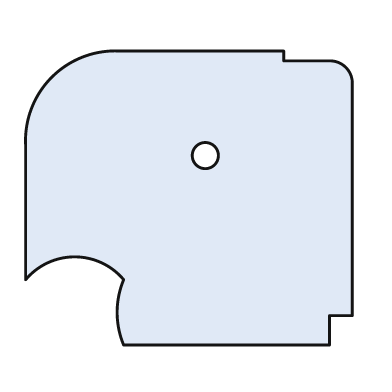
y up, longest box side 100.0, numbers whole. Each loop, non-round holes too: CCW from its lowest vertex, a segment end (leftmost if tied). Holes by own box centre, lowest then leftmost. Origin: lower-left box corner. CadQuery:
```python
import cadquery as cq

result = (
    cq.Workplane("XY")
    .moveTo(30.0, 0.0)
    .lineTo(93.0, 0.0)
    .lineTo(93.0, 9.0)
    .lineTo(100.0, 9.0)
    .lineTo(100.0, 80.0)
    .threePointArc((98.0, 85.0), (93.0, 87.0))
    .lineTo(79.0, 87.0)
    .lineTo(79.0, 90.0)
    .lineTo(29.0, 90.0)
    .threePointArc((8.0, 82.0), (0.0, 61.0))
    .lineTo(0.0, 20.0)
    .threePointArc((15.0, 27.0), (30.0, 20.0))
    .threePointArc((28.0, 10.0), (30.0, 0.0))
    .close()
    .moveTo(55.0, 58.0)
    .circle(4.0)
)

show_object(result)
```